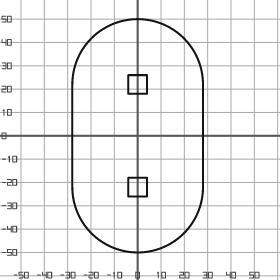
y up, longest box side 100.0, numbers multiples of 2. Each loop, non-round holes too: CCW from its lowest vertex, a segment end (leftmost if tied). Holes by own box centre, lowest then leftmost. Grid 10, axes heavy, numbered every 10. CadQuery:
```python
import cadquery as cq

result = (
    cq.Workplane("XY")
    .moveTo(-28.0, -22.0)
    .threePointArc((0.0, -50.0), (28.0, -22.0))
    .lineTo(28.0, 22.0)
    .threePointArc((0.0, 50.0), (-28.0, 22.0))
    .close()
    .moveTo(-4.0, -26.0)
    .lineTo(4.0, -26.0)
    .lineTo(4.0, -18.0)
    .lineTo(-4.0, -18.0)
    .close()
    .moveTo(-4.0, 18.0)
    .lineTo(4.0, 18.0)
    .lineTo(4.0, 26.0)
    .lineTo(-4.0, 26.0)
    .close()
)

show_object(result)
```